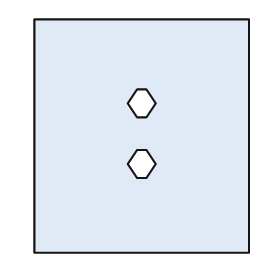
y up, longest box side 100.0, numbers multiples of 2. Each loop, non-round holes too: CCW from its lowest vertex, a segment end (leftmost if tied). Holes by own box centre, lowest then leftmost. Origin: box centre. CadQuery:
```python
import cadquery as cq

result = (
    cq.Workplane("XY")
    .moveTo(-46.0, -50.0)
    .lineTo(46.0, -50.0)
    .lineTo(46.0, 50.0)
    .lineTo(-46.0, 50.0)
    .close()
    .moveTo(-2.0, -18.0)
    .lineTo(2.0, -18.0)
    .lineTo(6.0, -12.0)
    .lineTo(2.0, -6.0)
    .lineTo(-2.0, -6.0)
    .lineTo(-6.0, -12.0)
    .close()
    .moveTo(-2.0, 8.0)
    .lineTo(2.0, 8.0)
    .lineTo(6.0, 14.0)
    .lineTo(2.0, 20.0)
    .lineTo(-2.0, 20.0)
    .lineTo(-6.0, 14.0)
    .close()
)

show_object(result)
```